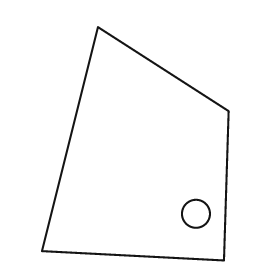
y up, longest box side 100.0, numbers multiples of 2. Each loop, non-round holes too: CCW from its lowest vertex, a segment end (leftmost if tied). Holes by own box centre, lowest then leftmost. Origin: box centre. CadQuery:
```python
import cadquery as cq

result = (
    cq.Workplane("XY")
    .moveTo(38.0, -50.0)
    .lineTo(40.0, 14.0)
    .lineTo(-16.0, 50.0)
    .lineTo(-40.0, -46.0)
    .close()
    .moveTo(26.0, -30.0)
    .circle(6.0)
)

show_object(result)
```